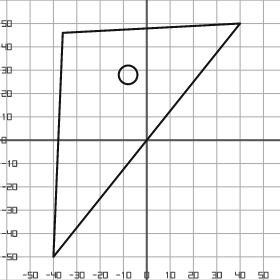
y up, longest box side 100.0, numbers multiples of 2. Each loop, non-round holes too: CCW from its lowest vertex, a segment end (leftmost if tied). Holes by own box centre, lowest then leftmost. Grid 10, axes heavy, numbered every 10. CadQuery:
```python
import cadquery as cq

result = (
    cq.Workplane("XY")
    .moveTo(-40.0, -50.0)
    .lineTo(40.0, 50.0)
    .lineTo(-36.0, 46.0)
    .close()
    .moveTo(-8.0, 28.0)
    .circle(4.0)
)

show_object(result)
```